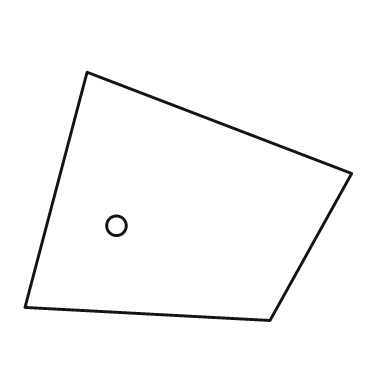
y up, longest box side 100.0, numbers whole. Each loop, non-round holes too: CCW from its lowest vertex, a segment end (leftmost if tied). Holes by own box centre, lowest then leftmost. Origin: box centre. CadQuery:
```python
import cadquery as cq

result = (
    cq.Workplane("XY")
    .moveTo(25.0, -38.0)
    .lineTo(50.0, 7.0)
    .lineTo(-31.0, 38.0)
    .lineTo(-50.0, -34.0)
    .close()
    .moveTo(-22.0, -9.0)
    .circle(3.0)
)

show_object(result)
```